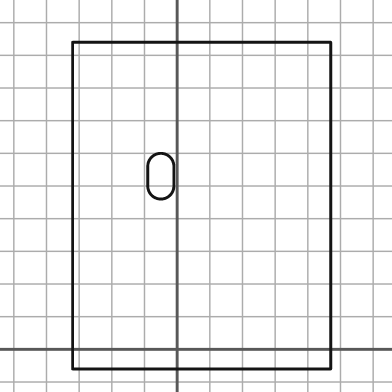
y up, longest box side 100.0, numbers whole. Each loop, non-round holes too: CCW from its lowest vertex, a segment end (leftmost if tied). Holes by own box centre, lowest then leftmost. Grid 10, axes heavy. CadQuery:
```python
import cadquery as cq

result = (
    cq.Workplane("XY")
    .moveTo(-32.0, -6.0)
    .lineTo(47.0, -6.0)
    .lineTo(47.0, 94.0)
    .lineTo(-32.0, 94.0)
    .close()
    .moveTo(-9.0, 50.0)
    .threePointArc((-5.0, 46.0), (-1.0, 50.0))
    .lineTo(-1.0, 56.0)
    .threePointArc((-5.0, 60.0), (-9.0, 56.0))
    .close()
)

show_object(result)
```